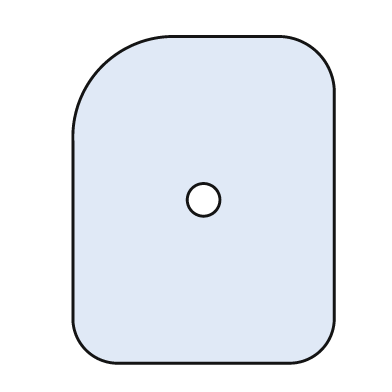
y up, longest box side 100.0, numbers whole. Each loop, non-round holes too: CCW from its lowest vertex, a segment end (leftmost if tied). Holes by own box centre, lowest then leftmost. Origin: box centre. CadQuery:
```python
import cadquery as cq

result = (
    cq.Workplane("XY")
    .moveTo(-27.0, -50.0)
    .lineTo(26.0, -50.0)
    .threePointArc((36.0, -46.0), (40.0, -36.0))
    .lineTo(40.0, 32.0)
    .threePointArc((35.0, 45.0), (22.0, 50.0))
    .lineTo(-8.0, 50.0)
    .threePointArc((-31.0, 41.0), (-40.0, 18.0))
    .lineTo(-40.0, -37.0)
    .threePointArc((-36.0, -46.0), (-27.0, -50.0))
    .close()
    .moveTo(0.0, 0.0)
    .circle(5.0)
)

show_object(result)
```